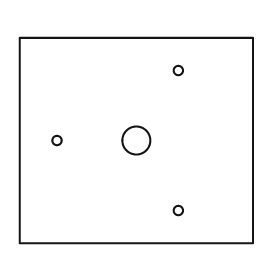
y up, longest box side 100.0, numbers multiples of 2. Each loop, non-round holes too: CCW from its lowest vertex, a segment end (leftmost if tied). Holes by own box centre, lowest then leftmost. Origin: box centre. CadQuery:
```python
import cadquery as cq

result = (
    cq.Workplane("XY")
    .moveTo(-50.0, -44.0)
    .lineTo(50.0, -44.0)
    .lineTo(50.0, 44.0)
    .lineTo(-50.0, 44.0)
    .close()
    .moveTo(18.0, -30.0)
    .circle(2.0)
    .moveTo(-34.0, 0.0)
    .circle(2.0)
    .moveTo(0.0, 0.0)
    .circle(6.0)
    .moveTo(18.0, 30.0)
    .circle(2.0)
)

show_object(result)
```